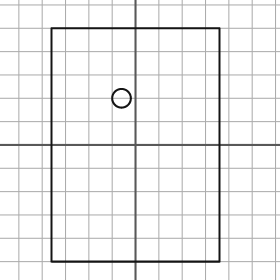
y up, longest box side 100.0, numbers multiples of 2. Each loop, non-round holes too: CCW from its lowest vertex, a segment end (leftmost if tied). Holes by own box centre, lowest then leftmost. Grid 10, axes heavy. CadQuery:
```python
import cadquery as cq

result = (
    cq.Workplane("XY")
    .moveTo(-36.0, -50.0)
    .lineTo(36.0, -50.0)
    .lineTo(36.0, 50.0)
    .lineTo(-36.0, 50.0)
    .close()
    .moveTo(-6.0, 20.0)
    .circle(4.0)
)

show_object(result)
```